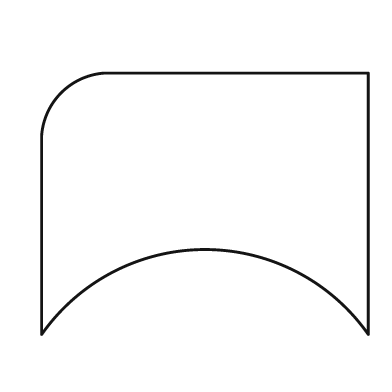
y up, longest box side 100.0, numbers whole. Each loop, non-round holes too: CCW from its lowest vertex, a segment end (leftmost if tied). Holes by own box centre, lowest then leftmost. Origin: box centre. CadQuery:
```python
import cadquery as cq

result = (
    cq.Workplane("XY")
    .moveTo(-50.0, -40.0)
    .threePointArc((0.0, -14.0), (50.0, -40.0))
    .lineTo(50.0, 40.0)
    .lineTo(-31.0, 40.0)
    .threePointArc((-44.0, 34.0), (-50.0, 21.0))
    .close()
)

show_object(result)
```